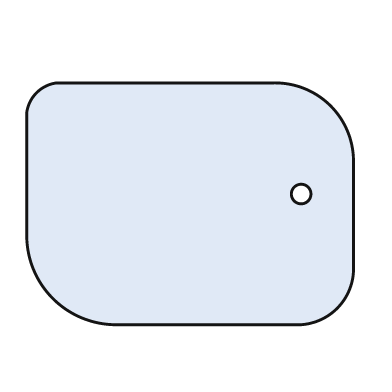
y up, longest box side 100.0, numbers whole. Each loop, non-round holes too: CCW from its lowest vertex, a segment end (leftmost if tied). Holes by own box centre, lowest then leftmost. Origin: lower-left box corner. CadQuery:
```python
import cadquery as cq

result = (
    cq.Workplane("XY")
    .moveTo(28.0, 0.0)
    .lineTo(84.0, 0.0)
    .threePointArc((95.0, 5.0), (100.0, 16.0))
    .lineTo(100.0, 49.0)
    .threePointArc((93.0, 67.0), (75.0, 74.0))
    .lineTo(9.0, 74.0)
    .threePointArc((3.0, 71.0), (0.0, 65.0))
    .lineTo(0.0, 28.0)
    .threePointArc((8.0, 8.0), (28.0, 0.0))
    .close()
    .moveTo(84.0, 40.0)
    .circle(3.0)
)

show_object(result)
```